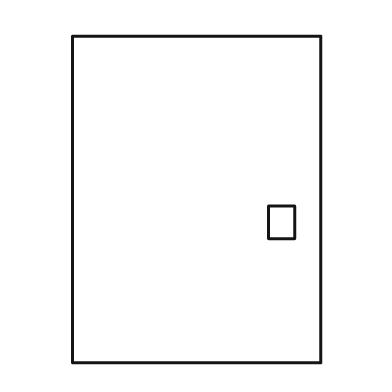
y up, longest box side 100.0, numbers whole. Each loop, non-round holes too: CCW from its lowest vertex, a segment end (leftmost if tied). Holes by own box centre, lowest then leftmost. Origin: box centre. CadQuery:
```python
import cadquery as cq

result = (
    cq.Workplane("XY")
    .moveTo(-38.0, -50.0)
    .lineTo(38.0, -50.0)
    .lineTo(38.0, 50.0)
    .lineTo(-38.0, 50.0)
    .close()
    .moveTo(22.0, -12.0)
    .lineTo(30.0, -12.0)
    .lineTo(30.0, -2.0)
    .lineTo(22.0, -2.0)
    .close()
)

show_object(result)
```